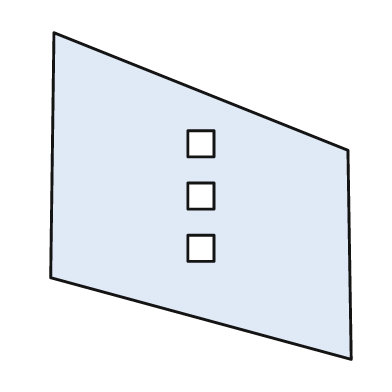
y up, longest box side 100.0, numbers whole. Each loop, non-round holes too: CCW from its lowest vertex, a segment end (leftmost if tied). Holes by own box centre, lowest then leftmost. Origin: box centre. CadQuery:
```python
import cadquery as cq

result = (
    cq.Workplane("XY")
    .moveTo(46.0, -50.0)
    .lineTo(45.0, 14.0)
    .lineTo(-45.0, 50.0)
    .lineTo(-46.0, -25.0)
    .close()
    .moveTo(-4.0, -20.0)
    .lineTo(4.0, -20.0)
    .lineTo(4.0, -12.0)
    .lineTo(-4.0, -12.0)
    .close()
    .moveTo(-4.0, -4.0)
    .lineTo(4.0, -4.0)
    .lineTo(4.0, 4.0)
    .lineTo(-4.0, 4.0)
    .close()
    .moveTo(-4.0, 12.0)
    .lineTo(4.0, 12.0)
    .lineTo(4.0, 20.0)
    .lineTo(-4.0, 20.0)
    .close()
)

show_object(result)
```